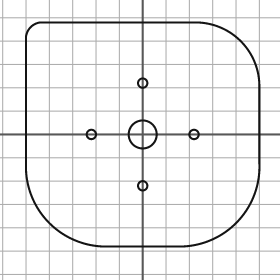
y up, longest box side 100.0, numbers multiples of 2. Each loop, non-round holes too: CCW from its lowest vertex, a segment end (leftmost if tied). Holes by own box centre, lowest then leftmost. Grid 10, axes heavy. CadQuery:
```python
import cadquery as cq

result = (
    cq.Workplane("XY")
    .moveTo(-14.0, -48.0)
    .lineTo(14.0, -48.0)
    .threePointArc((40.0, -38.0), (50.0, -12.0))
    .lineTo(50.0, 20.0)
    .threePointArc((42.0, 40.0), (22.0, 48.0))
    .lineTo(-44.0, 48.0)
    .threePointArc((-48.0, 46.0), (-50.0, 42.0))
    .lineTo(-50.0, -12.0)
    .threePointArc((-40.0, -38.0), (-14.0, -48.0))
    .close()
    .moveTo(0.0, -22.0)
    .circle(2.0)
    .moveTo(-22.0, 0.0)
    .circle(2.0)
    .moveTo(0.0, 0.0)
    .circle(6.0)
    .moveTo(22.0, 0.0)
    .circle(2.0)
    .moveTo(0.0, 22.0)
    .circle(2.0)
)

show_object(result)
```